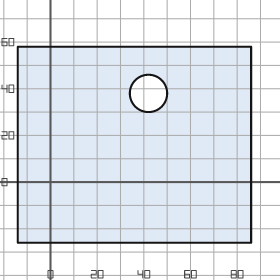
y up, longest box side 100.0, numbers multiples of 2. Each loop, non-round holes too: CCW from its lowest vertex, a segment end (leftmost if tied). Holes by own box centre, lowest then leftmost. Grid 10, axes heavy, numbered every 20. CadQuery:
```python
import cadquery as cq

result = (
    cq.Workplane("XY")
    .moveTo(-14.0, -26.0)
    .lineTo(86.0, -26.0)
    .lineTo(86.0, 58.0)
    .lineTo(-14.0, 58.0)
    .close()
    .moveTo(42.0, 38.0)
    .circle(8.0)
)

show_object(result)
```